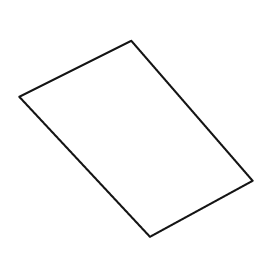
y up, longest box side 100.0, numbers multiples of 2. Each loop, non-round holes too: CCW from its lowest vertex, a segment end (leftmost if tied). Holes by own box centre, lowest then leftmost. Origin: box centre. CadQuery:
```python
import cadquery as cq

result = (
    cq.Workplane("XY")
    .moveTo(6.0, -42.0)
    .lineTo(50.0, -18.0)
    .lineTo(-2.0, 42.0)
    .lineTo(-50.0, 18.0)
    .close()
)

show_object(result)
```